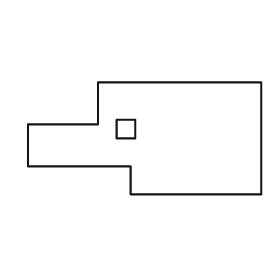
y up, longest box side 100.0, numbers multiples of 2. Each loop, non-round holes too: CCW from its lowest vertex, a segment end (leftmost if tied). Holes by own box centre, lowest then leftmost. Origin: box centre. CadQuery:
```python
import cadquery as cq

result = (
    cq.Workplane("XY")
    .moveTo(-6.0, -24.0)
    .lineTo(50.0, -24.0)
    .lineTo(50.0, 24.0)
    .lineTo(-20.0, 24.0)
    .lineTo(-20.0, 6.0)
    .lineTo(-50.0, 6.0)
    .lineTo(-50.0, -12.0)
    .lineTo(-6.0, -12.0)
    .close()
    .moveTo(-12.0, 0.0)
    .lineTo(-4.0, 0.0)
    .lineTo(-4.0, 8.0)
    .lineTo(-12.0, 8.0)
    .close()
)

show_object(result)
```